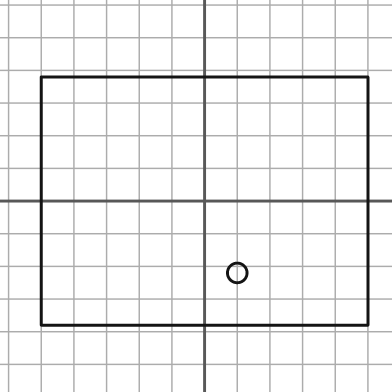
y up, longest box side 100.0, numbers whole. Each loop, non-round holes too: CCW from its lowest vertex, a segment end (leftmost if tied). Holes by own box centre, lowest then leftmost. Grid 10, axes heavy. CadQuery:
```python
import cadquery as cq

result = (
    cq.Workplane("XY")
    .moveTo(-50.0, -38.0)
    .lineTo(50.0, -38.0)
    .lineTo(50.0, 38.0)
    .lineTo(-50.0, 38.0)
    .close()
    .moveTo(10.0, -22.0)
    .circle(3.0)
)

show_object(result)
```